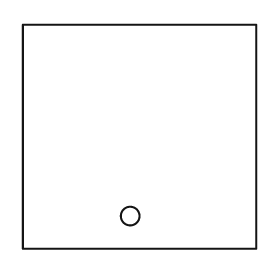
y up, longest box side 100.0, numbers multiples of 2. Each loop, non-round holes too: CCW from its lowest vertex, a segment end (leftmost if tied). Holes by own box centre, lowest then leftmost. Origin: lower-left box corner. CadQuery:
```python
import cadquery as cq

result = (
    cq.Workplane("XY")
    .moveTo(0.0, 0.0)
    .lineTo(100.0, 0.0)
    .lineTo(100.0, 96.0)
    .lineTo(0.0, 96.0)
    .close()
    .moveTo(46.0, 14.0)
    .circle(4.0)
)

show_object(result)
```